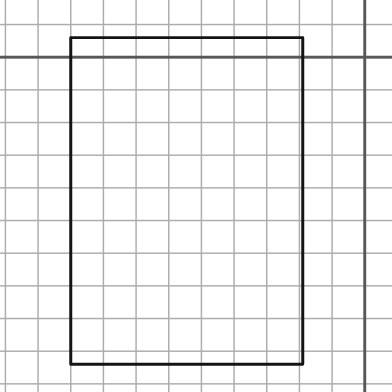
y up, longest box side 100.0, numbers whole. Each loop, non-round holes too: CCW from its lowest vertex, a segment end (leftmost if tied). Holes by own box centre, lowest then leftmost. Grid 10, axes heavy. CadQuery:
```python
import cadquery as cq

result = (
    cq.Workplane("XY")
    .moveTo(-90.0, -94.0)
    .lineTo(-19.0, -94.0)
    .lineTo(-19.0, 6.0)
    .lineTo(-90.0, 6.0)
    .close()
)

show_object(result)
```